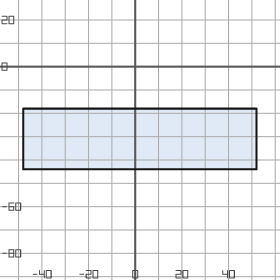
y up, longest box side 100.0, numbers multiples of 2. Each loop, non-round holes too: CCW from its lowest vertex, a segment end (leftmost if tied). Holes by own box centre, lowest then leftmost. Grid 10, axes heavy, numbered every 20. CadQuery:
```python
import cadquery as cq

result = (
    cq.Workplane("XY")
    .moveTo(-48.0, -44.0)
    .lineTo(52.0, -44.0)
    .lineTo(52.0, -18.0)
    .lineTo(-48.0, -18.0)
    .close()
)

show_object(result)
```